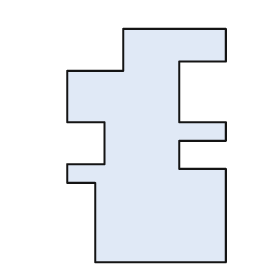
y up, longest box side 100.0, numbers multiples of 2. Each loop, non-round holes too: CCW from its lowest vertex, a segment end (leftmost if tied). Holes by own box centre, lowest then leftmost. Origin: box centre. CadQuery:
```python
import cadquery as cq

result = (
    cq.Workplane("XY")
    .moveTo(-22.0, -50.0)
    .lineTo(34.0, -50.0)
    .lineTo(34.0, -10.0)
    .lineTo(14.0, -10.0)
    .lineTo(14.0, 2.0)
    .lineTo(34.0, 2.0)
    .lineTo(34.0, 10.0)
    .lineTo(14.0, 10.0)
    .lineTo(14.0, 36.0)
    .lineTo(34.0, 36.0)
    .lineTo(34.0, 50.0)
    .lineTo(-10.0, 50.0)
    .lineTo(-10.0, 32.0)
    .lineTo(-34.0, 32.0)
    .lineTo(-34.0, 10.0)
    .lineTo(-18.0, 10.0)
    .lineTo(-18.0, -8.0)
    .lineTo(-34.0, -8.0)
    .lineTo(-34.0, -16.0)
    .lineTo(-22.0, -16.0)
    .close()
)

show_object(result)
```